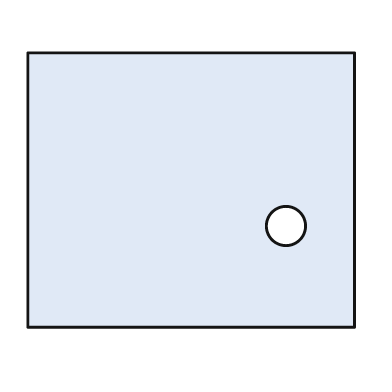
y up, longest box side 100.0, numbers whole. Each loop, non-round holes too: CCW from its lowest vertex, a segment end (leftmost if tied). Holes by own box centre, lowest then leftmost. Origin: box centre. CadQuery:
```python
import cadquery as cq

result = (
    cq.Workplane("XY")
    .moveTo(-50.0, -42.0)
    .lineTo(50.0, -42.0)
    .lineTo(50.0, 42.0)
    .lineTo(-50.0, 42.0)
    .close()
    .moveTo(29.0, -11.0)
    .circle(6.0)
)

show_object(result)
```